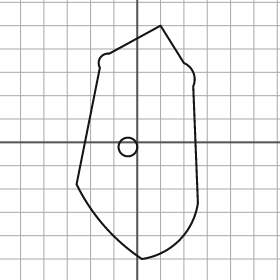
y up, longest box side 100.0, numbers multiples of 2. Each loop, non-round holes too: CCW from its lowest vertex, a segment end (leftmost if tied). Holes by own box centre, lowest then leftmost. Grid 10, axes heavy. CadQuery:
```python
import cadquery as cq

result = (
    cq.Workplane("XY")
    .moveTo(2.0, -50.0)
    .threePointArc((18.0, -42.0), (26.0, -26.0))
    .lineTo(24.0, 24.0)
    .threePointArc((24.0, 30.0), (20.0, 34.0))
    .lineTo(10.0, 50.0)
    .lineTo(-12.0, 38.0)
    .threePointArc((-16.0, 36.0), (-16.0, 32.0))
    .lineTo(-26.0, -18.0)
    .threePointArc((-14.0, -36.0), (2.0, -50.0))
    .close()
    .moveTo(-4.0, -2.0)
    .circle(4.0)
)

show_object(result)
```